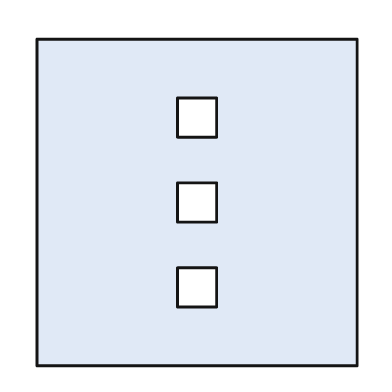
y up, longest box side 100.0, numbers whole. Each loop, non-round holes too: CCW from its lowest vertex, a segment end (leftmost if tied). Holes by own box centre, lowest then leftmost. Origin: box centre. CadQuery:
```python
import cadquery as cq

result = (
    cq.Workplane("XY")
    .moveTo(-49.0, -50.0)
    .lineTo(49.0, -50.0)
    .lineTo(49.0, 50.0)
    .lineTo(-49.0, 50.0)
    .close()
    .moveTo(-6.0, -32.0)
    .lineTo(6.0, -32.0)
    .lineTo(6.0, -20.0)
    .lineTo(-6.0, -20.0)
    .close()
    .moveTo(-6.0, -6.0)
    .lineTo(6.0, -6.0)
    .lineTo(6.0, 6.0)
    .lineTo(-6.0, 6.0)
    .close()
    .moveTo(-6.0, 20.0)
    .lineTo(6.0, 20.0)
    .lineTo(6.0, 32.0)
    .lineTo(-6.0, 32.0)
    .close()
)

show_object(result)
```